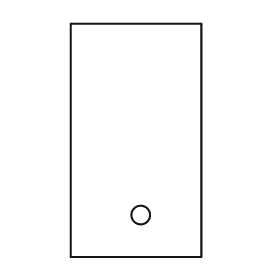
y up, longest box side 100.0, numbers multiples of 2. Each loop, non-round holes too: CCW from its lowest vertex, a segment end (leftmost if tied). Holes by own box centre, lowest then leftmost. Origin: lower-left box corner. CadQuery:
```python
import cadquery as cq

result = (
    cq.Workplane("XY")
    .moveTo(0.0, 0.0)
    .lineTo(56.0, 0.0)
    .lineTo(56.0, 100.0)
    .lineTo(0.0, 100.0)
    .close()
    .moveTo(30.0, 18.0)
    .circle(4.0)
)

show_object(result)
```